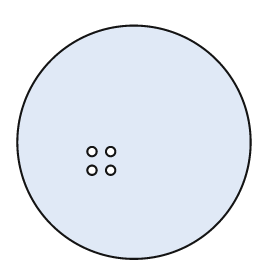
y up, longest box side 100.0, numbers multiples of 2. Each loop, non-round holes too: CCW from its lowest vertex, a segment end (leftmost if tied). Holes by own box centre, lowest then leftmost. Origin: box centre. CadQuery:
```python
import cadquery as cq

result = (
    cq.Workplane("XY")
    .moveTo(0.0, 0.0)
    .circle(50.0)
    .moveTo(-18.0, -12.0)
    .circle(2.0)
    .moveTo(-10.0, -12.0)
    .circle(2.0)
    .moveTo(-18.0, -4.0)
    .circle(2.0)
    .moveTo(-10.0, -4.0)
    .circle(2.0)
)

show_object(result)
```